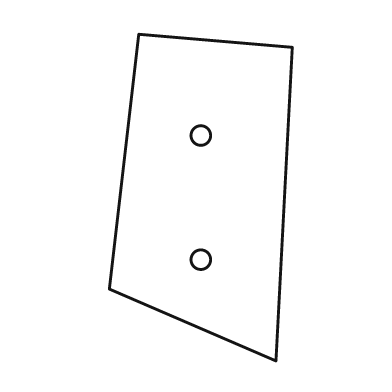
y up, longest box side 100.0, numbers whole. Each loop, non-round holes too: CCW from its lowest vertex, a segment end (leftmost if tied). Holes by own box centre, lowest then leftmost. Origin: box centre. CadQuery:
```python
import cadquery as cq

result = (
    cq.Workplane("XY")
    .moveTo(23.0, -50.0)
    .lineTo(28.0, 46.0)
    .lineTo(-19.0, 50.0)
    .lineTo(-28.0, -28.0)
    .close()
    .moveTo(0.0, -19.0)
    .circle(3.0)
    .moveTo(0.0, 19.0)
    .circle(3.0)
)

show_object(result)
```